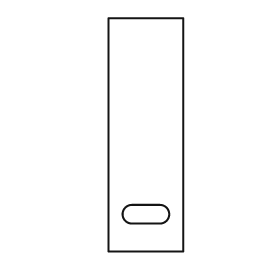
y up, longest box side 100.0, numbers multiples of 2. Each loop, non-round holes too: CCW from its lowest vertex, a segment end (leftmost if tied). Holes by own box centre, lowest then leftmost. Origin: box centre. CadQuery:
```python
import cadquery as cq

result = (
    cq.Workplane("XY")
    .moveTo(-16.0, -50.0)
    .lineTo(16.0, -50.0)
    .lineTo(16.0, 50.0)
    .lineTo(-16.0, 50.0)
    .close()
    .moveTo(-6.0, -38.0)
    .lineTo(6.0, -38.0)
    .threePointArc((10.0, -34.0), (6.0, -30.0))
    .lineTo(-6.0, -30.0)
    .threePointArc((-10.0, -34.0), (-6.0, -38.0))
    .close()
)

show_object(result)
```